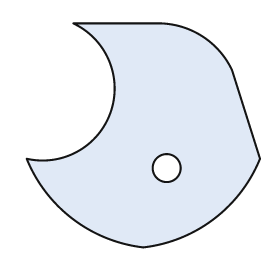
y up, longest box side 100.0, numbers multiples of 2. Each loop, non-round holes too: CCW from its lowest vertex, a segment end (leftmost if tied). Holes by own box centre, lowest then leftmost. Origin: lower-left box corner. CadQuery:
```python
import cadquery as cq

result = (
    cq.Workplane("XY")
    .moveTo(50.0, 0.0)
    .threePointArc((80.0, 12.0), (100.0, 38.0))
    .lineTo(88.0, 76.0)
    .threePointArc((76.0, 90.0), (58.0, 96.0))
    .lineTo(20.0, 96.0)
    .threePointArc((36.0, 58.0), (0.0, 38.0))
    .threePointArc((20.0, 12.0), (50.0, 0.0))
    .close()
    .moveTo(60.0, 34.0)
    .circle(6.0)
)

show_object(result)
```